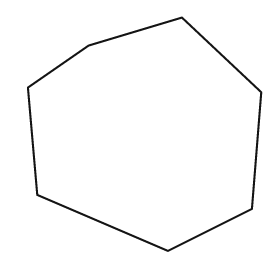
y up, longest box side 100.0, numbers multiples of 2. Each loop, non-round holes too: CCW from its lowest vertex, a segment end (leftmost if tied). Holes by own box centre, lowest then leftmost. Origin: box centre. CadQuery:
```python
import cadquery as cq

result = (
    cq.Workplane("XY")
    .moveTo(10.0, -50.0)
    .lineTo(46.0, -32.0)
    .lineTo(50.0, 18.0)
    .lineTo(16.0, 50.0)
    .lineTo(-24.0, 38.0)
    .lineTo(-50.0, 20.0)
    .lineTo(-46.0, -26.0)
    .close()
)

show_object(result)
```